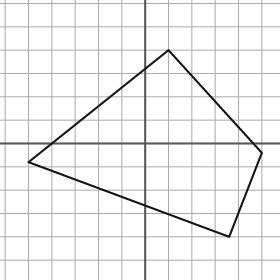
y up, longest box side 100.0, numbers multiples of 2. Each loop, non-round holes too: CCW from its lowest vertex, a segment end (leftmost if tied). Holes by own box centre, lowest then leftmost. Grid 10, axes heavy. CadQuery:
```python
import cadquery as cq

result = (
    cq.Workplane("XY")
    .moveTo(36.0, -40.0)
    .lineTo(50.0, -4.0)
    .lineTo(10.0, 40.0)
    .lineTo(-50.0, -8.0)
    .close()
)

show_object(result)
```